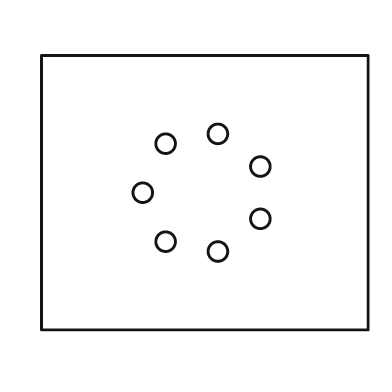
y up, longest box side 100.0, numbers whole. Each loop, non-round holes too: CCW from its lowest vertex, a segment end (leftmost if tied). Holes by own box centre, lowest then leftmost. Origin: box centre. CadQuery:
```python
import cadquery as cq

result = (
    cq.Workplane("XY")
    .moveTo(-50.0, -42.0)
    .lineTo(50.0, -42.0)
    .lineTo(50.0, 42.0)
    .lineTo(-50.0, 42.0)
    .close()
    .moveTo(4.0, -18.0)
    .circle(3.0)
    .moveTo(-12.0, -15.0)
    .circle(3.0)
    .moveTo(17.0, -8.0)
    .circle(3.0)
    .moveTo(-19.0, 0.0)
    .circle(3.0)
    .moveTo(17.0, 8.0)
    .circle(3.0)
    .moveTo(-12.0, 15.0)
    .circle(3.0)
    .moveTo(4.0, 18.0)
    .circle(3.0)
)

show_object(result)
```